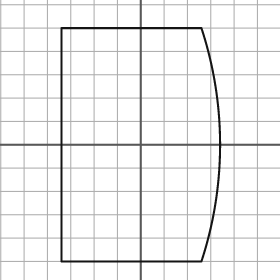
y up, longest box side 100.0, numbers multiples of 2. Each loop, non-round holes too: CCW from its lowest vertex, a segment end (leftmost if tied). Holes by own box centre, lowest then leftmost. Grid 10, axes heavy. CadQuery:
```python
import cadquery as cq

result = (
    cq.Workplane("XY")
    .moveTo(-34.0, -50.0)
    .lineTo(26.0, -50.0)
    .threePointArc((34.0, 0.0), (26.0, 50.0))
    .lineTo(-34.0, 50.0)
    .close()
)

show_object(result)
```